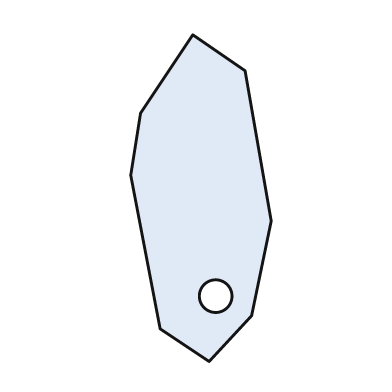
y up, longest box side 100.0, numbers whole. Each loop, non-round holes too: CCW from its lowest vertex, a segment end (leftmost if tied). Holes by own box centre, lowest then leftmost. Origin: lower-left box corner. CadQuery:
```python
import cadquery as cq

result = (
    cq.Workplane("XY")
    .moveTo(24.0, 0.0)
    .lineTo(37.0, 14.0)
    .lineTo(43.0, 43.0)
    .lineTo(35.0, 89.0)
    .lineTo(19.0, 100.0)
    .lineTo(3.0, 76.0)
    .lineTo(0.0, 57.0)
    .lineTo(9.0, 10.0)
    .close()
    .moveTo(26.0, 20.0)
    .circle(5.0)
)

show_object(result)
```